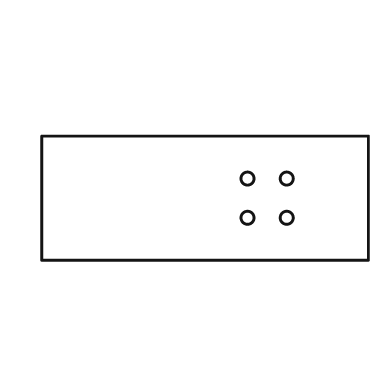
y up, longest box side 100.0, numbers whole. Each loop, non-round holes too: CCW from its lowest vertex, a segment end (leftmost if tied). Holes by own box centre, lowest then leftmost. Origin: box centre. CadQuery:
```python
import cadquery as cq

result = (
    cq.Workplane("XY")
    .moveTo(-50.0, -19.0)
    .lineTo(50.0, -19.0)
    .lineTo(50.0, 19.0)
    .lineTo(-50.0, 19.0)
    .close()
    .moveTo(13.0, -6.0)
    .circle(2.0)
    .moveTo(25.0, -6.0)
    .circle(2.0)
    .moveTo(13.0, 6.0)
    .circle(2.0)
    .moveTo(25.0, 6.0)
    .circle(2.0)
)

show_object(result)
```